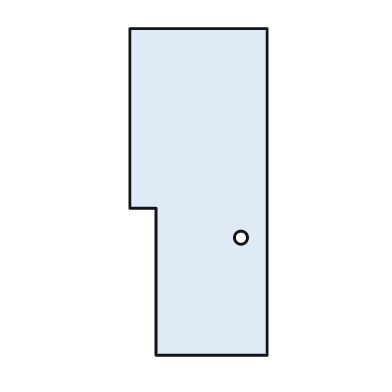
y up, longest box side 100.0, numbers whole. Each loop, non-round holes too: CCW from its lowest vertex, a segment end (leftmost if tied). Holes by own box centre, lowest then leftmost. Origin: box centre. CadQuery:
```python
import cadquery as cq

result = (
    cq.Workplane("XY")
    .moveTo(-13.0, -50.0)
    .lineTo(21.0, -50.0)
    .lineTo(21.0, 50.0)
    .lineTo(-21.0, 50.0)
    .lineTo(-21.0, -5.0)
    .lineTo(-13.0, -5.0)
    .close()
    .moveTo(13.0, -14.0)
    .circle(2.0)
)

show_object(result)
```